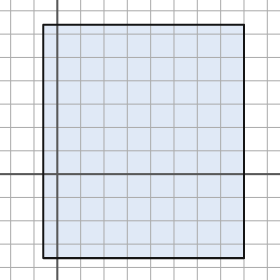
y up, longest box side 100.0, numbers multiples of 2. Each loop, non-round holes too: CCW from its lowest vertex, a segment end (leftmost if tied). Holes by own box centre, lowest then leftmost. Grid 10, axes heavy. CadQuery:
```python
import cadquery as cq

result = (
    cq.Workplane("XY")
    .moveTo(-6.0, -36.0)
    .lineTo(80.0, -36.0)
    .lineTo(80.0, 64.0)
    .lineTo(-6.0, 64.0)
    .close()
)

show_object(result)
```